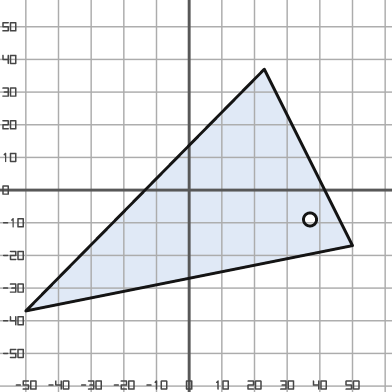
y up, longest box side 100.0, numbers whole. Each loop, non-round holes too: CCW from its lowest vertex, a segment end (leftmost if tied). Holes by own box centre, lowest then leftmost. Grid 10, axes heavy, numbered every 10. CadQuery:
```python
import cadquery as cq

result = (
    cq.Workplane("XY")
    .moveTo(-50.0, -37.0)
    .lineTo(50.0, -17.0)
    .lineTo(23.0, 37.0)
    .close()
    .moveTo(37.0, -9.0)
    .circle(2.0)
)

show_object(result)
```